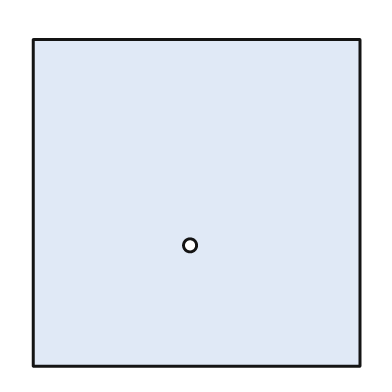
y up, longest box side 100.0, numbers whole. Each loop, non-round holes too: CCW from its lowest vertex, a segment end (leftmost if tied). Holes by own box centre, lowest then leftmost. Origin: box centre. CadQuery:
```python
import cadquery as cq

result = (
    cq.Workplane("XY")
    .moveTo(-50.0, -50.0)
    .lineTo(50.0, -50.0)
    .lineTo(50.0, 50.0)
    .lineTo(-50.0, 50.0)
    .close()
    .moveTo(-2.0, -13.0)
    .circle(2.0)
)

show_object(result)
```